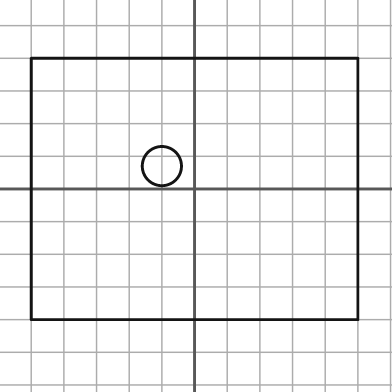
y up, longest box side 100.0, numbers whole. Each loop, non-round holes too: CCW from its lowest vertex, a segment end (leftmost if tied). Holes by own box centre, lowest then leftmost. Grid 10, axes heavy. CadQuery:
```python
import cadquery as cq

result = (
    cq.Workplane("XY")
    .moveTo(-50.0, -40.0)
    .lineTo(50.0, -40.0)
    .lineTo(50.0, 40.0)
    .lineTo(-50.0, 40.0)
    .close()
    .moveTo(-10.0, 7.0)
    .circle(6.0)
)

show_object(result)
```